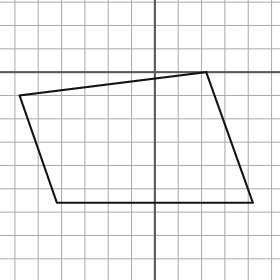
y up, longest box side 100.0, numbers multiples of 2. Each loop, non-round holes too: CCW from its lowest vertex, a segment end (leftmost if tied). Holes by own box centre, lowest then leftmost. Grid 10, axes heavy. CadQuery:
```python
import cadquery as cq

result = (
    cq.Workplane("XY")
    .moveTo(-42.0, -56.0)
    .lineTo(42.0, -56.0)
    .lineTo(22.0, 0.0)
    .lineTo(-58.0, -10.0)
    .close()
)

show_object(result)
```